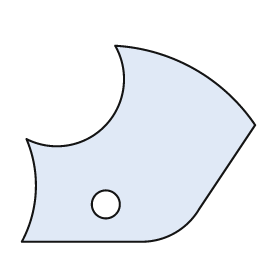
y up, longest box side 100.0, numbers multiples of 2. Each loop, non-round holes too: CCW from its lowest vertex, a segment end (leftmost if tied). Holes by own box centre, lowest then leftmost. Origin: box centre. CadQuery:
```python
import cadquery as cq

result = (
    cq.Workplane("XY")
    .moveTo(-50.0, -42.0)
    .lineTo(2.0, -42.0)
    .threePointArc((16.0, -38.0), (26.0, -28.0))
    .lineTo(50.0, 8.0)
    .threePointArc((24.0, 32.0), (-10.0, 42.0))
    .threePointArc((-14.0, 8.0), (-48.0, 2.0))
    .threePointArc((-44.0, -20.0), (-50.0, -42.0))
    .close()
    .moveTo(-14.0, -26.0)
    .circle(6.0)
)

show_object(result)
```